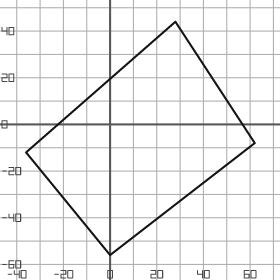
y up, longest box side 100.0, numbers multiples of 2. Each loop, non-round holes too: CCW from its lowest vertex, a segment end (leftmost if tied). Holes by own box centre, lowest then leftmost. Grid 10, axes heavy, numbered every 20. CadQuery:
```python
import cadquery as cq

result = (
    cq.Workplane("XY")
    .moveTo(0.0, -56.0)
    .lineTo(62.0, -8.0)
    .lineTo(28.0, 44.0)
    .lineTo(-36.0, -12.0)
    .close()
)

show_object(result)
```